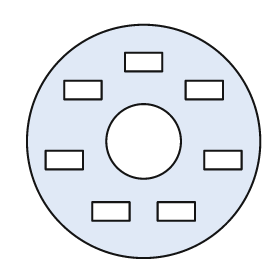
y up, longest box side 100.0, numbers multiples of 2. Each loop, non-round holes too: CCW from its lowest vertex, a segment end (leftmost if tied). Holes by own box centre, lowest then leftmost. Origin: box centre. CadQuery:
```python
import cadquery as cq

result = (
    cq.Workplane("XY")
    .moveTo(0.0, 0.0)
    .circle(50.0)
    .moveTo(-22.0, -34.0)
    .lineTo(-6.0, -34.0)
    .lineTo(-6.0, -26.0)
    .lineTo(-22.0, -26.0)
    .close()
    .moveTo(6.0, -34.0)
    .lineTo(22.0, -34.0)
    .lineTo(22.0, -26.0)
    .lineTo(6.0, -26.0)
    .close()
    .moveTo(-42.0, -12.0)
    .lineTo(-26.0, -12.0)
    .lineTo(-26.0, -4.0)
    .lineTo(-42.0, -4.0)
    .close()
    .moveTo(26.0, -12.0)
    .lineTo(42.0, -12.0)
    .lineTo(42.0, -4.0)
    .lineTo(26.0, -4.0)
    .close()
    .moveTo(0.0, 0.0)
    .circle(16.0)
    .moveTo(-34.0, 18.0)
    .lineTo(-18.0, 18.0)
    .lineTo(-18.0, 26.0)
    .lineTo(-34.0, 26.0)
    .close()
    .moveTo(18.0, 18.0)
    .lineTo(34.0, 18.0)
    .lineTo(34.0, 26.0)
    .lineTo(18.0, 26.0)
    .close()
    .moveTo(-8.0, 30.0)
    .lineTo(8.0, 30.0)
    .lineTo(8.0, 38.0)
    .lineTo(-8.0, 38.0)
    .close()
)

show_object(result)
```